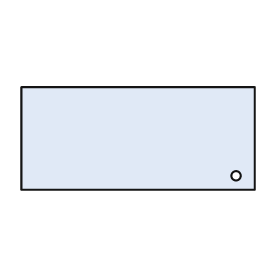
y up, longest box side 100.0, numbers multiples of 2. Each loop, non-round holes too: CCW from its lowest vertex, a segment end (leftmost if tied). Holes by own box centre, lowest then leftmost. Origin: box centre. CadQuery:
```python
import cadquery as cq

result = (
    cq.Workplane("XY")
    .moveTo(-50.0, -22.0)
    .lineTo(50.0, -22.0)
    .lineTo(50.0, 22.0)
    .lineTo(-50.0, 22.0)
    .close()
    .moveTo(42.0, -16.0)
    .circle(2.0)
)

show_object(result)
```